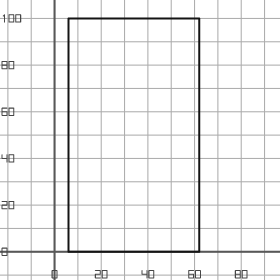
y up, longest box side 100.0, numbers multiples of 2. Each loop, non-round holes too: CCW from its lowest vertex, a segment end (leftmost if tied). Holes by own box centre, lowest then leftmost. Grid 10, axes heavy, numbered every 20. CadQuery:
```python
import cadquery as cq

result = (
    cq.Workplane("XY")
    .moveTo(6.0, 0.0)
    .lineTo(62.0, 0.0)
    .lineTo(62.0, 100.0)
    .lineTo(6.0, 100.0)
    .close()
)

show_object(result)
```